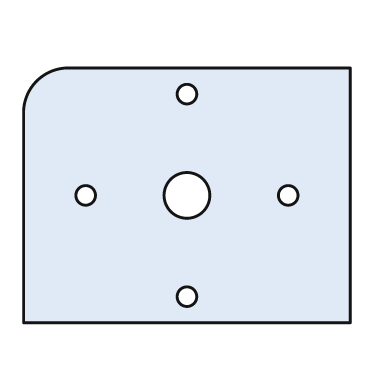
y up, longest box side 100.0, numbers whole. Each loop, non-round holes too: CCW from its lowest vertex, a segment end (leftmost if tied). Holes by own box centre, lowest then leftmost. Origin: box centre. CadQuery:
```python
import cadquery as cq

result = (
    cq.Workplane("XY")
    .moveTo(-50.0, -39.0)
    .lineTo(50.0, -39.0)
    .lineTo(50.0, 39.0)
    .lineTo(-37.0, 39.0)
    .threePointArc((-46.0, 35.0), (-50.0, 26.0))
    .close()
    .moveTo(0.0, -31.0)
    .circle(3.0)
    .moveTo(-31.0, 0.0)
    .circle(3.0)
    .moveTo(0.0, 0.0)
    .circle(7.0)
    .moveTo(31.0, 0.0)
    .circle(3.0)
    .moveTo(0.0, 31.0)
    .circle(3.0)
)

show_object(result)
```